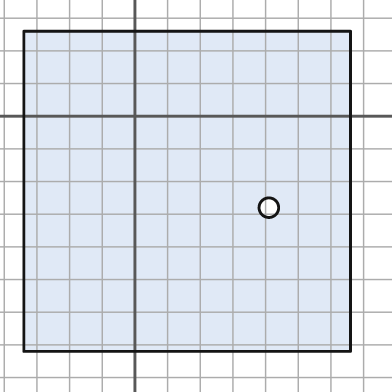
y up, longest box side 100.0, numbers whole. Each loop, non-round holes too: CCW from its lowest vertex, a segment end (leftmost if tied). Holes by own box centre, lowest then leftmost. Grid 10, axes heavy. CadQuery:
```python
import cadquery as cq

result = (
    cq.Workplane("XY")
    .moveTo(-34.0, -72.0)
    .lineTo(66.0, -72.0)
    .lineTo(66.0, 26.0)
    .lineTo(-34.0, 26.0)
    .close()
    .moveTo(41.0, -28.0)
    .circle(3.0)
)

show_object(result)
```